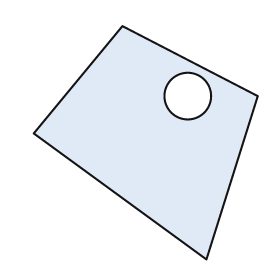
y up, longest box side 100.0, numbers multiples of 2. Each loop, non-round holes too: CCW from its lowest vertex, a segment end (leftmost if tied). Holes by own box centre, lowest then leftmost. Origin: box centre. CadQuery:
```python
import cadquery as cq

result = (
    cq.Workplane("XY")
    .moveTo(26.0, -50.0)
    .lineTo(48.0, 20.0)
    .lineTo(-10.0, 50.0)
    .lineTo(-48.0, 4.0)
    .close()
    .moveTo(18.0, 20.0)
    .circle(10.0)
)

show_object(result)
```